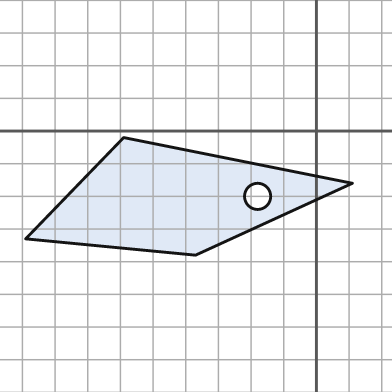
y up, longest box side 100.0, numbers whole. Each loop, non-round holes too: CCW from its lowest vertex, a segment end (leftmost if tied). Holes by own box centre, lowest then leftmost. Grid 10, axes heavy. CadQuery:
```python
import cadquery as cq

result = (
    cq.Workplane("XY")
    .moveTo(-37.0, -38.0)
    .lineTo(11.0, -16.0)
    .lineTo(-59.0, -2.0)
    .lineTo(-89.0, -33.0)
    .close()
    .moveTo(-18.0, -20.0)
    .circle(4.0)
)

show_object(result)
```